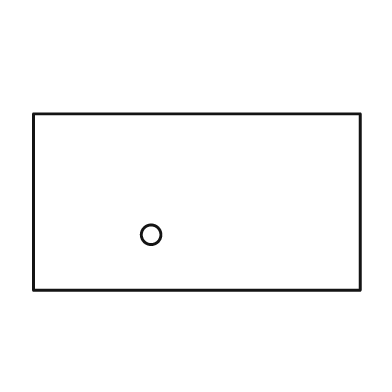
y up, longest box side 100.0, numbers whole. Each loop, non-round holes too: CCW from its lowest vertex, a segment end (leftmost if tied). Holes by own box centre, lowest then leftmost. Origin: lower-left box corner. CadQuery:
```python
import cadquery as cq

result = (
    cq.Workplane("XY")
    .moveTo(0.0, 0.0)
    .lineTo(100.0, 0.0)
    .lineTo(100.0, 54.0)
    .lineTo(0.0, 54.0)
    .close()
    .moveTo(36.0, 17.0)
    .circle(3.0)
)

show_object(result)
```